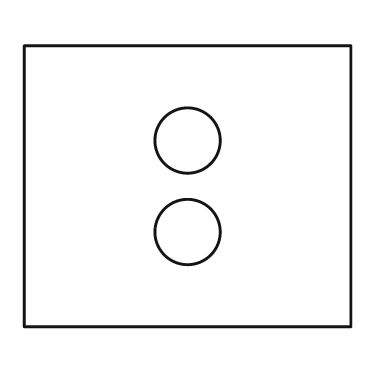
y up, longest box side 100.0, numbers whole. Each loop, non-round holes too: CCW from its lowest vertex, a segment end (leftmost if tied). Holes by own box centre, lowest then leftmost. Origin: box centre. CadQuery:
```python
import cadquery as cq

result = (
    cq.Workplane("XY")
    .moveTo(-50.0, -43.0)
    .lineTo(50.0, -43.0)
    .lineTo(50.0, 43.0)
    .lineTo(-50.0, 43.0)
    .close()
    .moveTo(0.0, -14.0)
    .circle(10.0)
    .moveTo(0.0, 14.0)
    .circle(10.0)
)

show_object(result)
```